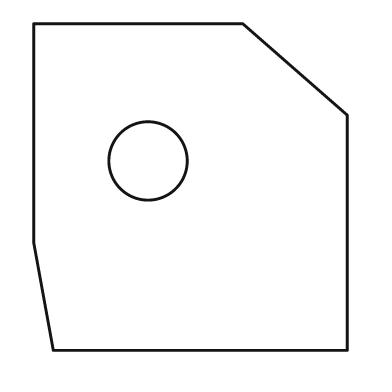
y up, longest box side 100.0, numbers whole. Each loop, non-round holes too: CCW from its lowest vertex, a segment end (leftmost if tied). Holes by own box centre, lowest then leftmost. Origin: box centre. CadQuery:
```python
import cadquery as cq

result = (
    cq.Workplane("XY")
    .moveTo(-42.0, -50.0)
    .lineTo(48.0, -50.0)
    .lineTo(48.0, 22.0)
    .lineTo(16.0, 50.0)
    .lineTo(-48.0, 50.0)
    .lineTo(-48.0, -17.0)
    .close()
    .moveTo(-13.0, 8.0)
    .circle(12.0)
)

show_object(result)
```